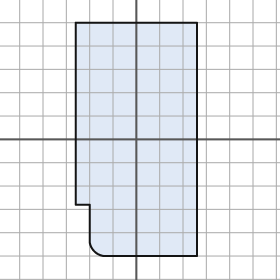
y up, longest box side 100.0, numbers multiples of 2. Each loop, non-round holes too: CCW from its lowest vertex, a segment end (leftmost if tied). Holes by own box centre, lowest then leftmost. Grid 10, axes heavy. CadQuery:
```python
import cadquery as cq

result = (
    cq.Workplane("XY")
    .moveTo(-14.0, -50.0)
    .lineTo(26.0, -50.0)
    .lineTo(26.0, 50.0)
    .lineTo(-26.0, 50.0)
    .lineTo(-26.0, -28.0)
    .lineTo(-20.0, -28.0)
    .lineTo(-20.0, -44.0)
    .threePointArc((-18.0, -48.0), (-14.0, -50.0))
    .close()
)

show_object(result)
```